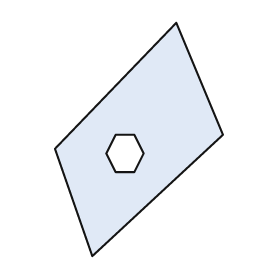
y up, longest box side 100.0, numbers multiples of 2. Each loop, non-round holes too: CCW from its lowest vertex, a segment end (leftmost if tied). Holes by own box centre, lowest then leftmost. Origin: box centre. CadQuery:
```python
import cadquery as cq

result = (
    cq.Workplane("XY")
    .moveTo(-20.0, -50.0)
    .lineTo(36.0, 2.0)
    .lineTo(16.0, 50.0)
    .lineTo(-36.0, -4.0)
    .close()
    .moveTo(-10.0, -14.0)
    .lineTo(-2.0, -14.0)
    .lineTo(2.0, -6.0)
    .lineTo(-2.0, 2.0)
    .lineTo(-10.0, 2.0)
    .lineTo(-14.0, -6.0)
    .close()
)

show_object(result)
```